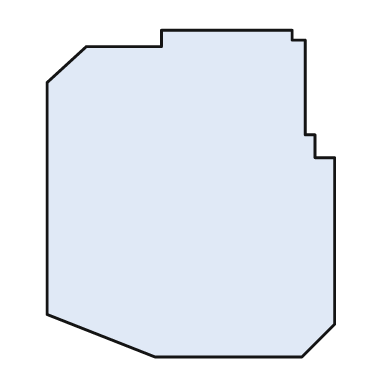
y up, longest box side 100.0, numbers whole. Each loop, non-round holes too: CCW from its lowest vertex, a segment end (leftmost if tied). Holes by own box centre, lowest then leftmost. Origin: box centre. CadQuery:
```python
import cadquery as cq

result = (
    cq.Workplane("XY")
    .moveTo(-11.0, -50.0)
    .lineTo(34.0, -50.0)
    .lineTo(44.0, -40.0)
    .lineTo(44.0, 11.0)
    .lineTo(38.0, 11.0)
    .lineTo(38.0, 18.0)
    .lineTo(35.0, 18.0)
    .lineTo(35.0, 47.0)
    .lineTo(31.0, 47.0)
    .lineTo(31.0, 50.0)
    .lineTo(-9.0, 50.0)
    .lineTo(-9.0, 45.0)
    .lineTo(-32.0, 45.0)
    .lineTo(-44.0, 34.0)
    .lineTo(-44.0, -37.0)
    .close()
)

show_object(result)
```